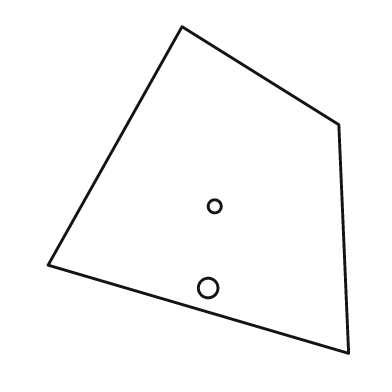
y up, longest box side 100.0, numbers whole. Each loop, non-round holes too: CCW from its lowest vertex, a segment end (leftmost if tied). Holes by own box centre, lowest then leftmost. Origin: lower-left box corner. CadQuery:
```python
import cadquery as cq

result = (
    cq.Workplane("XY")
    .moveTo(92.0, 0.0)
    .lineTo(89.0, 70.0)
    .lineTo(41.0, 100.0)
    .lineTo(0.0, 27.0)
    .close()
    .moveTo(49.0, 20.0)
    .circle(3.0)
    .moveTo(51.0, 45.0)
    .circle(2.0)
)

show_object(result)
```